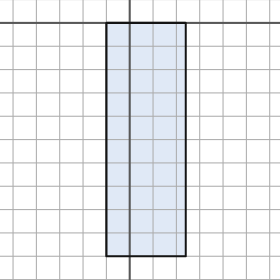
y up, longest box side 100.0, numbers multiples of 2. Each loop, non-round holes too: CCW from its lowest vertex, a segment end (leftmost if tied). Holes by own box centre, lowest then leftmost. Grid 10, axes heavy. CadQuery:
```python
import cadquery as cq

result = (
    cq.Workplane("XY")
    .moveTo(-10.0, -100.0)
    .lineTo(24.0, -100.0)
    .lineTo(24.0, 0.0)
    .lineTo(-10.0, 0.0)
    .close()
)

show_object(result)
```